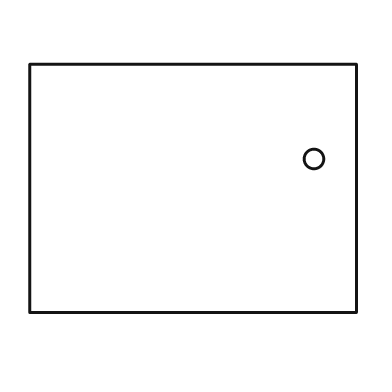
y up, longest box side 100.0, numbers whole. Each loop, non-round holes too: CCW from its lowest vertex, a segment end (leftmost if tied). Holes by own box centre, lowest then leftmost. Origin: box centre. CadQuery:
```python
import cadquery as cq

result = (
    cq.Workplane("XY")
    .moveTo(-50.0, -38.0)
    .lineTo(50.0, -38.0)
    .lineTo(50.0, 38.0)
    .lineTo(-50.0, 38.0)
    .close()
    .moveTo(37.0, 9.0)
    .circle(3.0)
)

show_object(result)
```